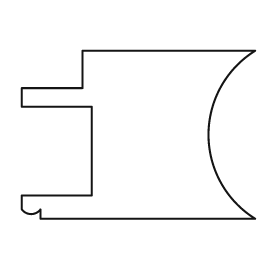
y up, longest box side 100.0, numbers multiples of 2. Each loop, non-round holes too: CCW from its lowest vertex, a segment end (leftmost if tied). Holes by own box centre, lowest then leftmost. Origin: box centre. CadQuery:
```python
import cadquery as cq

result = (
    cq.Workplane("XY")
    .moveTo(-42.0, -36.0)
    .lineTo(50.0, -36.0)
    .threePointArc((30.0, 0.0), (50.0, 36.0))
    .lineTo(-24.0, 36.0)
    .lineTo(-24.0, 20.0)
    .lineTo(-50.0, 20.0)
    .lineTo(-50.0, 12.0)
    .lineTo(-20.0, 12.0)
    .lineTo(-20.0, -26.0)
    .lineTo(-50.0, -26.0)
    .lineTo(-50.0, -32.0)
    .threePointArc((-46.0, -34.0), (-42.0, -32.0))
    .close()
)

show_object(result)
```